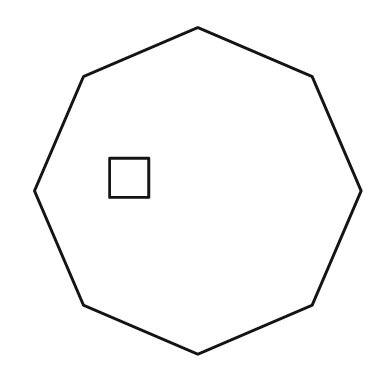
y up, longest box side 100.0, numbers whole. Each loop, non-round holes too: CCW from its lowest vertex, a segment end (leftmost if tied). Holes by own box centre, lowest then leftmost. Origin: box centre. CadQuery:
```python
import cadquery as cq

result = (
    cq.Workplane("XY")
    .moveTo(0.0, -50.0)
    .lineTo(35.0, -35.0)
    .lineTo(50.0, 0.0)
    .lineTo(35.0, 35.0)
    .lineTo(0.0, 50.0)
    .lineTo(-35.0, 35.0)
    .lineTo(-50.0, 0.0)
    .lineTo(-35.0, -35.0)
    .close()
    .moveTo(-27.0, -2.0)
    .lineTo(-15.0, -2.0)
    .lineTo(-15.0, 10.0)
    .lineTo(-27.0, 10.0)
    .close()
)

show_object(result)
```